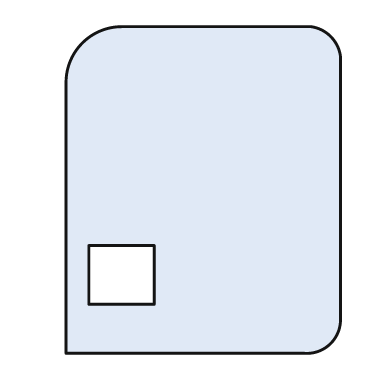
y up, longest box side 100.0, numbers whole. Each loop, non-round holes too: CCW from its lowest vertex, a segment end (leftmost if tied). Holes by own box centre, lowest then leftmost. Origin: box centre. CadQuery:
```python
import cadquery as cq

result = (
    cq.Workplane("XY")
    .moveTo(-42.0, -50.0)
    .lineTo(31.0, -50.0)
    .threePointArc((39.0, -47.0), (42.0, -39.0))
    .lineTo(42.0, 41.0)
    .threePointArc((39.0, 47.0), (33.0, 50.0))
    .lineTo(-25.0, 50.0)
    .threePointArc((-37.0, 45.0), (-42.0, 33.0))
    .close()
    .moveTo(-35.0, -35.0)
    .lineTo(-15.0, -35.0)
    .lineTo(-15.0, -17.0)
    .lineTo(-35.0, -17.0)
    .close()
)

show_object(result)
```